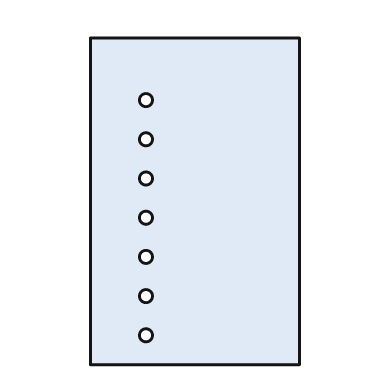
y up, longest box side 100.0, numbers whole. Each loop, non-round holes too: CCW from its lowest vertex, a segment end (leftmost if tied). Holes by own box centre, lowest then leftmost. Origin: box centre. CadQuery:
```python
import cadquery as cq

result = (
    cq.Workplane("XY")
    .moveTo(-32.0, -50.0)
    .lineTo(32.0, -50.0)
    .lineTo(32.0, 50.0)
    .lineTo(-32.0, 50.0)
    .close()
    .moveTo(-15.0, -41.0)
    .circle(2.0)
    .moveTo(-15.0, -29.0)
    .circle(2.0)
    .moveTo(-15.0, -17.0)
    .circle(2.0)
    .moveTo(-15.0, -5.0)
    .circle(2.0)
    .moveTo(-15.0, 7.0)
    .circle(2.0)
    .moveTo(-15.0, 19.0)
    .circle(2.0)
    .moveTo(-15.0, 31.0)
    .circle(2.0)
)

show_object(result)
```